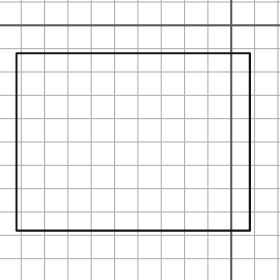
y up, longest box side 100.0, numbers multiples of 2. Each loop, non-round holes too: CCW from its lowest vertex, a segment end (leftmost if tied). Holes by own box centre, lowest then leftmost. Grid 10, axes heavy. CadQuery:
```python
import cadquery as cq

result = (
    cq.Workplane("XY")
    .moveTo(-92.0, -88.0)
    .lineTo(8.0, -88.0)
    .lineTo(8.0, -12.0)
    .lineTo(-92.0, -12.0)
    .close()
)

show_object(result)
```